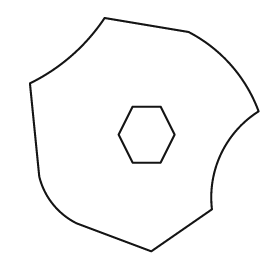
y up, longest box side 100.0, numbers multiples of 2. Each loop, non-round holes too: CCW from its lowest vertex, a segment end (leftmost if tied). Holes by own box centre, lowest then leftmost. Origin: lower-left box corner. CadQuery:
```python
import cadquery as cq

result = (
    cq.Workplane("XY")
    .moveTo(52.0, 0.0)
    .lineTo(78.0, 18.0)
    .threePointArc((82.0, 42.0), (98.0, 60.0))
    .threePointArc((86.0, 80.0), (68.0, 94.0))
    .lineTo(32.0, 100.0)
    .threePointArc((18.0, 84.0), (0.0, 72.0))
    .lineTo(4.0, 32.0)
    .threePointArc((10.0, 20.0), (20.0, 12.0))
    .close()
    .moveTo(44.0, 38.0)
    .lineTo(56.0, 38.0)
    .lineTo(62.0, 50.0)
    .lineTo(56.0, 62.0)
    .lineTo(44.0, 62.0)
    .lineTo(38.0, 50.0)
    .close()
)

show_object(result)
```